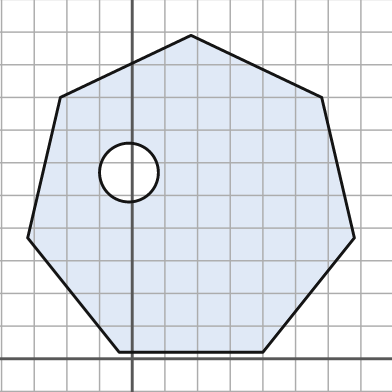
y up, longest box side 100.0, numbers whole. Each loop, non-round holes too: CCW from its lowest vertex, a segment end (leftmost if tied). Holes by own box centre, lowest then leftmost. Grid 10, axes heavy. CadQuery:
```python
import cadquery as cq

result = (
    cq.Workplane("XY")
    .moveTo(-4.0, 2.0)
    .lineTo(40.0, 2.0)
    .lineTo(68.0, 37.0)
    .lineTo(58.0, 80.0)
    .lineTo(18.0, 99.0)
    .lineTo(-22.0, 80.0)
    .lineTo(-32.0, 37.0)
    .close()
    .moveTo(-1.0, 57.0)
    .circle(9.0)
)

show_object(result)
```